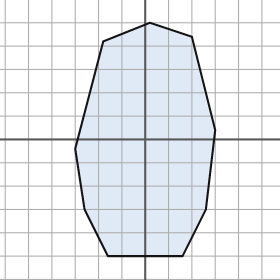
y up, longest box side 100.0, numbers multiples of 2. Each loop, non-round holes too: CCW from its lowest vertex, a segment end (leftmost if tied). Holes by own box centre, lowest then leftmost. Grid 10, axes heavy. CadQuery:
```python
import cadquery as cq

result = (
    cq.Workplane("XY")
    .moveTo(-16.0, -50.0)
    .lineTo(16.0, -50.0)
    .lineTo(26.0, -30.0)
    .lineTo(30.0, 4.0)
    .lineTo(20.0, 44.0)
    .lineTo(2.0, 50.0)
    .lineTo(-18.0, 42.0)
    .lineTo(-30.0, -4.0)
    .lineTo(-26.0, -30.0)
    .close()
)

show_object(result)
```